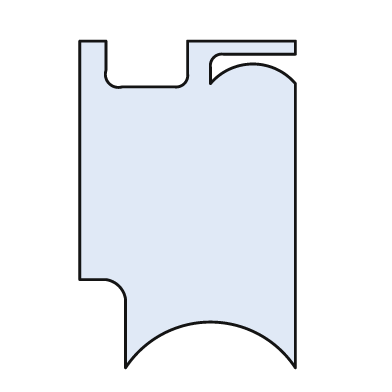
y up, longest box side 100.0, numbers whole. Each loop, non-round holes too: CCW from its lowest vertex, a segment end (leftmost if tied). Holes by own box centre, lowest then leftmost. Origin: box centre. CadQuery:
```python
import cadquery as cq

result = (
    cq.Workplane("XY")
    .moveTo(-19.0, -50.0)
    .threePointArc((7.0, -36.0), (33.0, -50.0))
    .lineTo(33.0, 37.0)
    .threePointArc((20.0, 43.0), (7.0, 37.0))
    .lineTo(7.0, 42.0)
    .threePointArc((8.0, 45.0), (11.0, 46.0))
    .lineTo(33.0, 46.0)
    .lineTo(33.0, 50.0)
    .lineTo(0.0, 50.0)
    .lineTo(0.0, 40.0)
    .threePointArc((-1.0, 37.0), (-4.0, 36.0))
    .lineTo(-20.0, 36.0)
    .threePointArc((-24.0, 37.0), (-25.0, 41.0))
    .lineTo(-25.0, 50.0)
    .lineTo(-33.0, 50.0)
    .lineTo(-33.0, -23.0)
    .lineTo(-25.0, -23.0)
    .threePointArc((-21.0, -25.0), (-19.0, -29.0))
    .close()
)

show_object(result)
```